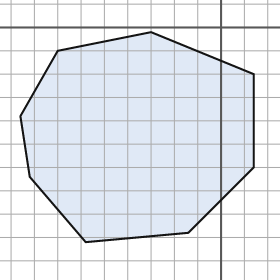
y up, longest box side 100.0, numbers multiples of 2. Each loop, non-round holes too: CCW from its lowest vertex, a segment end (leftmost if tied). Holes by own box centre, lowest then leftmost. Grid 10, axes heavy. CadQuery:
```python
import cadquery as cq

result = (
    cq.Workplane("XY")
    .moveTo(-58.0, -92.0)
    .lineTo(-14.0, -88.0)
    .lineTo(14.0, -60.0)
    .lineTo(14.0, -20.0)
    .lineTo(-30.0, -2.0)
    .lineTo(-70.0, -10.0)
    .lineTo(-86.0, -38.0)
    .lineTo(-82.0, -64.0)
    .close()
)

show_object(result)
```